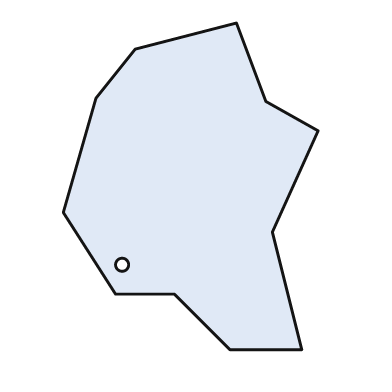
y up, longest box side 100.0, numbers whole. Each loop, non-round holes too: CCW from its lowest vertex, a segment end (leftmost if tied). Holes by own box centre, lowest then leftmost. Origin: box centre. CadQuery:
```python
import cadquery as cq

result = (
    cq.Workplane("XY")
    .moveTo(12.0, -50.0)
    .lineTo(34.0, -50.0)
    .lineTo(25.0, -14.0)
    .lineTo(39.0, 17.0)
    .lineTo(23.0, 26.0)
    .lineTo(14.0, 50.0)
    .lineTo(-17.0, 42.0)
    .lineTo(-29.0, 27.0)
    .lineTo(-39.0, -8.0)
    .lineTo(-23.0, -33.0)
    .lineTo(-5.0, -33.0)
    .close()
    .moveTo(-21.0, -24.0)
    .circle(2.0)
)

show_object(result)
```